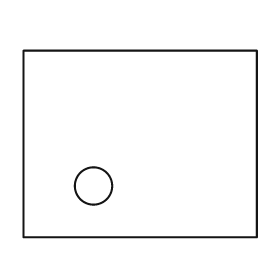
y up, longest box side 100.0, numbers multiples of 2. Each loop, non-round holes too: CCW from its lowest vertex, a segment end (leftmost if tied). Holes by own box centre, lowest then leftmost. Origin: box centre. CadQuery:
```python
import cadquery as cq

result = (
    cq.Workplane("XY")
    .moveTo(-50.0, -40.0)
    .lineTo(50.0, -40.0)
    .lineTo(50.0, 40.0)
    .lineTo(-50.0, 40.0)
    .close()
    .moveTo(-20.0, -18.0)
    .circle(8.0)
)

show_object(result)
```